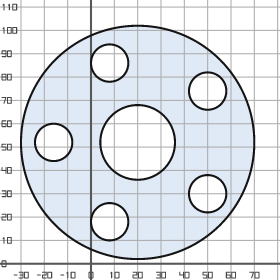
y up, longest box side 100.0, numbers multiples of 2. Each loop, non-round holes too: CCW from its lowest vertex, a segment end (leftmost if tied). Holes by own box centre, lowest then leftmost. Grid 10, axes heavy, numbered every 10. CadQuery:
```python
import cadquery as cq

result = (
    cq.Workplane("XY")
    .moveTo(20.0, 52.0)
    .circle(50.0)
    .moveTo(8.0, 18.0)
    .circle(8.0)
    .moveTo(50.0, 30.0)
    .circle(8.0)
    .moveTo(-16.0, 52.0)
    .circle(8.0)
    .moveTo(20.0, 52.0)
    .circle(16.0)
    .moveTo(50.0, 74.0)
    .circle(8.0)
    .moveTo(8.0, 86.0)
    .circle(8.0)
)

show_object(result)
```